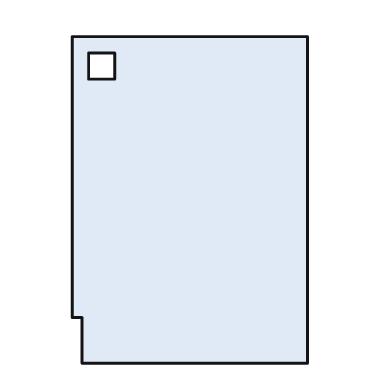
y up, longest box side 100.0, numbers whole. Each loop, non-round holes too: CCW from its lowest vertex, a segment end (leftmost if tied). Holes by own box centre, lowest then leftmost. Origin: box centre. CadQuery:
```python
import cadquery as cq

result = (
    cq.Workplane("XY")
    .moveTo(-33.0, -50.0)
    .lineTo(36.0, -50.0)
    .lineTo(36.0, 50.0)
    .lineTo(-36.0, 50.0)
    .lineTo(-36.0, -36.0)
    .lineTo(-33.0, -36.0)
    .close()
    .moveTo(-31.0, 37.0)
    .lineTo(-23.0, 37.0)
    .lineTo(-23.0, 45.0)
    .lineTo(-31.0, 45.0)
    .close()
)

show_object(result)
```